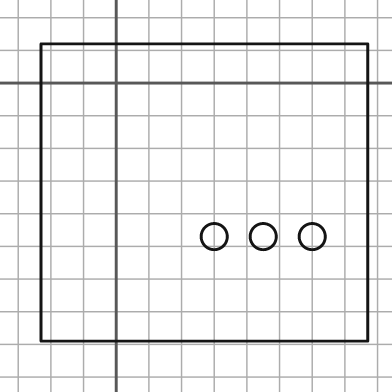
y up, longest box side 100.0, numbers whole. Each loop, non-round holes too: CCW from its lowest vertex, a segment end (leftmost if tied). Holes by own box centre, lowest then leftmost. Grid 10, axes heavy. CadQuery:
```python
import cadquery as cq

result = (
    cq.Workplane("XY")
    .moveTo(-23.0, -79.0)
    .lineTo(77.0, -79.0)
    .lineTo(77.0, 12.0)
    .lineTo(-23.0, 12.0)
    .close()
    .moveTo(30.0, -47.0)
    .circle(4.0)
    .moveTo(45.0, -47.0)
    .circle(4.0)
    .moveTo(60.0, -47.0)
    .circle(4.0)
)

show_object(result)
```